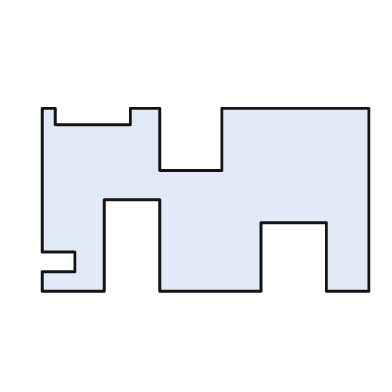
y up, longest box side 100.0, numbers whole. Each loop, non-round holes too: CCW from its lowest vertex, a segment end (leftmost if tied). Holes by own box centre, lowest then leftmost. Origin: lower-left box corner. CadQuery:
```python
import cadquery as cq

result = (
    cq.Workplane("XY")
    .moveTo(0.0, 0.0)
    .lineTo(19.0, 0.0)
    .lineTo(19.0, 28.0)
    .lineTo(36.0, 28.0)
    .lineTo(36.0, 0.0)
    .lineTo(67.0, 0.0)
    .lineTo(67.0, 21.0)
    .lineTo(87.0, 21.0)
    .lineTo(87.0, 0.0)
    .lineTo(100.0, 0.0)
    .lineTo(100.0, 56.0)
    .lineTo(55.0, 56.0)
    .lineTo(55.0, 37.0)
    .lineTo(36.0, 37.0)
    .lineTo(36.0, 56.0)
    .lineTo(27.0, 56.0)
    .lineTo(27.0, 51.0)
    .lineTo(4.0, 51.0)
    .lineTo(4.0, 56.0)
    .lineTo(0.0, 56.0)
    .lineTo(0.0, 12.0)
    .lineTo(10.0, 12.0)
    .lineTo(10.0, 6.0)
    .lineTo(0.0, 6.0)
    .close()
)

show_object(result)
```